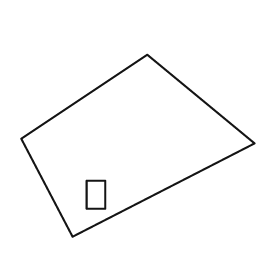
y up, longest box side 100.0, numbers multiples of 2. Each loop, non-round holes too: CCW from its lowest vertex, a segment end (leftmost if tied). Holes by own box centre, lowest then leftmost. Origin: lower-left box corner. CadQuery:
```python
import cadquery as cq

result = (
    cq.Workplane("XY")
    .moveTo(22.0, 0.0)
    .lineTo(100.0, 40.0)
    .lineTo(54.0, 78.0)
    .lineTo(0.0, 42.0)
    .close()
    .moveTo(28.0, 12.0)
    .lineTo(36.0, 12.0)
    .lineTo(36.0, 24.0)
    .lineTo(28.0, 24.0)
    .close()
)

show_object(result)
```